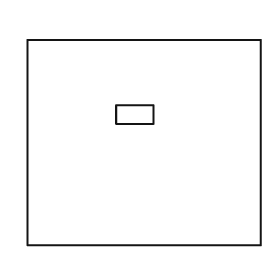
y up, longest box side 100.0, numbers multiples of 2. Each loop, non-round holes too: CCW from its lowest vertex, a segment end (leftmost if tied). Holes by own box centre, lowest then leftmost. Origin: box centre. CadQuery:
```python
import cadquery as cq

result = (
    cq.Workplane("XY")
    .moveTo(-50.0, -44.0)
    .lineTo(50.0, -44.0)
    .lineTo(50.0, 44.0)
    .lineTo(-50.0, 44.0)
    .close()
    .moveTo(-12.0, 8.0)
    .lineTo(4.0, 8.0)
    .lineTo(4.0, 16.0)
    .lineTo(-12.0, 16.0)
    .close()
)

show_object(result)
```